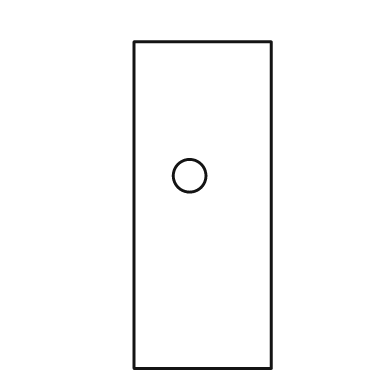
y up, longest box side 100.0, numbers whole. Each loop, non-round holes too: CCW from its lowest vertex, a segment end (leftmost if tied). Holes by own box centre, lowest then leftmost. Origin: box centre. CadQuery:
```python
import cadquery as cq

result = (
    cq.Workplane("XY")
    .moveTo(-21.0, -50.0)
    .lineTo(21.0, -50.0)
    .lineTo(21.0, 50.0)
    .lineTo(-21.0, 50.0)
    .close()
    .moveTo(-4.0, 9.0)
    .circle(5.0)
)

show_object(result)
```